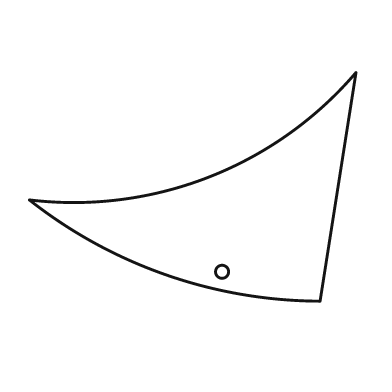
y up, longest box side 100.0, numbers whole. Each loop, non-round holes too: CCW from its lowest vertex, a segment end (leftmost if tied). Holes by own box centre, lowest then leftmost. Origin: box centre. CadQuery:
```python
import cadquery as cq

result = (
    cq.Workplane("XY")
    .moveTo(39.0, -35.0)
    .lineTo(50.0, 35.0)
    .threePointArc((5.0, 3.0), (-50.0, -4.0))
    .threePointArc((-8.0, -27.0), (39.0, -35.0))
    .close()
    .moveTo(9.0, -26.0)
    .circle(2.0)
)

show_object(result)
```